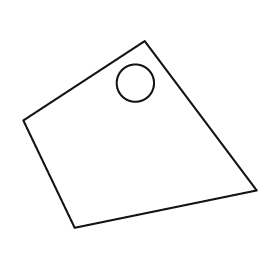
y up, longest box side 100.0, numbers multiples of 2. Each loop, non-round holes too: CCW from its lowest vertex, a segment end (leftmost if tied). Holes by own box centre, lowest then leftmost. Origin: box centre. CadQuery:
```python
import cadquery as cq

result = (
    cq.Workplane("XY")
    .moveTo(-28.0, -40.0)
    .lineTo(50.0, -24.0)
    .lineTo(2.0, 40.0)
    .lineTo(-50.0, 6.0)
    .close()
    .moveTo(-2.0, 22.0)
    .circle(8.0)
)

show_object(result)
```